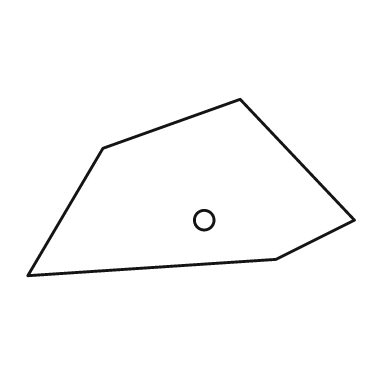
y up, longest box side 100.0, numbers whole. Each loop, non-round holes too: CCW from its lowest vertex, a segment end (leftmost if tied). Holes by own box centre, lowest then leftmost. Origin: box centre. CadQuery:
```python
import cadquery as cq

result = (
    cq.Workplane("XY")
    .moveTo(-50.0, -27.0)
    .lineTo(26.0, -22.0)
    .lineTo(50.0, -10.0)
    .lineTo(15.0, 27.0)
    .lineTo(-27.0, 12.0)
    .close()
    .moveTo(4.0, -10.0)
    .circle(3.0)
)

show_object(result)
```